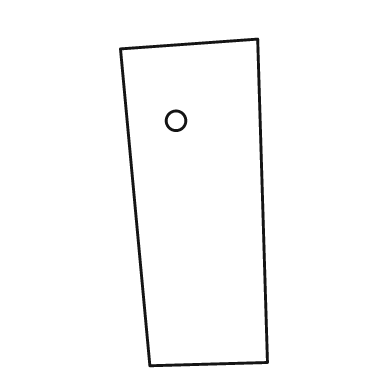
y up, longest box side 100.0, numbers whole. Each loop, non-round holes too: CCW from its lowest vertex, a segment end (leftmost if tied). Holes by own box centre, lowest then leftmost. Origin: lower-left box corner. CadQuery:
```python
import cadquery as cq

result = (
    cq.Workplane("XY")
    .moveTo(9.0, 0.0)
    .lineTo(45.0, 1.0)
    .lineTo(42.0, 100.0)
    .lineTo(0.0, 97.0)
    .close()
    .moveTo(17.0, 75.0)
    .circle(3.0)
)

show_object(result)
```